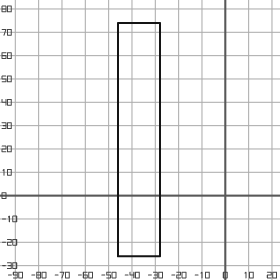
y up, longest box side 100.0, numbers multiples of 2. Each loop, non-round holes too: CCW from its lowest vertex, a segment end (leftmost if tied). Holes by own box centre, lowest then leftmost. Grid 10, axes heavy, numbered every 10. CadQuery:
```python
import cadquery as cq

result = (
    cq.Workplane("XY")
    .moveTo(-46.0, -26.0)
    .lineTo(-28.0, -26.0)
    .lineTo(-28.0, 74.0)
    .lineTo(-46.0, 74.0)
    .close()
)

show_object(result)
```